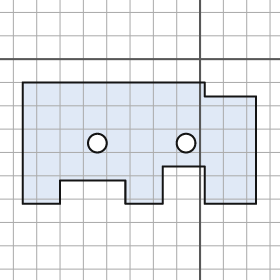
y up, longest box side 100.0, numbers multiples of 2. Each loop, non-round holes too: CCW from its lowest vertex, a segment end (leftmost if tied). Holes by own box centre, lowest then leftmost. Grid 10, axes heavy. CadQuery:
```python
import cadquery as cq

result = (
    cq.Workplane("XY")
    .moveTo(-76.0, -62.0)
    .lineTo(-60.0, -62.0)
    .lineTo(-60.0, -52.0)
    .lineTo(-32.0, -52.0)
    .lineTo(-32.0, -62.0)
    .lineTo(-16.0, -62.0)
    .lineTo(-16.0, -46.0)
    .lineTo(2.0, -46.0)
    .lineTo(2.0, -62.0)
    .lineTo(24.0, -62.0)
    .lineTo(24.0, -16.0)
    .lineTo(2.0, -16.0)
    .lineTo(2.0, -10.0)
    .lineTo(-76.0, -10.0)
    .close()
    .moveTo(-44.0, -36.0)
    .circle(4.0)
    .moveTo(-6.0, -36.0)
    .circle(4.0)
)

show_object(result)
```